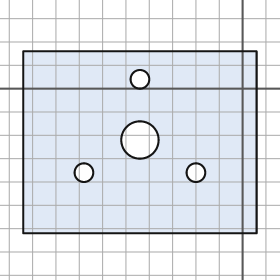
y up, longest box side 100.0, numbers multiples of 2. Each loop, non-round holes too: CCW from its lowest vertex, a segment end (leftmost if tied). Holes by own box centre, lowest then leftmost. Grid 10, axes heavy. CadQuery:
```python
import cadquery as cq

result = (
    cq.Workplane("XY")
    .moveTo(-94.0, -62.0)
    .lineTo(6.0, -62.0)
    .lineTo(6.0, 16.0)
    .lineTo(-94.0, 16.0)
    .close()
    .moveTo(-68.0, -36.0)
    .circle(4.0)
    .moveTo(-20.0, -36.0)
    .circle(4.0)
    .moveTo(-44.0, -22.0)
    .circle(8.0)
    .moveTo(-44.0, 4.0)
    .circle(4.0)
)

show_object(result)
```